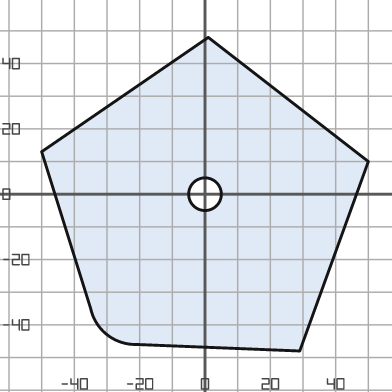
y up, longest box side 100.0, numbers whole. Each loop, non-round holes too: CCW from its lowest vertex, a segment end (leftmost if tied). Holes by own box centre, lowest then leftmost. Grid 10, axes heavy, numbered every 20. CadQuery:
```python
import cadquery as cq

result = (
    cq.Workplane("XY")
    .moveTo(29.0, -48.0)
    .lineTo(50.0, 10.0)
    .lineTo(1.0, 48.0)
    .lineTo(-50.0, 13.0)
    .lineTo(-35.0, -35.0)
    .threePointArc((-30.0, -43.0), (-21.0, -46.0))
    .close()
    .moveTo(0.0, 0.0)
    .circle(5.0)
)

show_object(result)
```